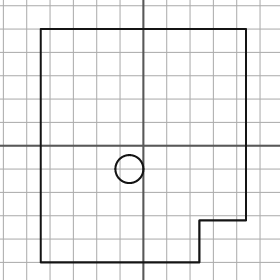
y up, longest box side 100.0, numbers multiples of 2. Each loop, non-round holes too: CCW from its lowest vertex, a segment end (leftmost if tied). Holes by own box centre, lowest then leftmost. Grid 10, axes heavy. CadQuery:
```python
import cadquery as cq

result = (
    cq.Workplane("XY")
    .moveTo(-44.0, -50.0)
    .lineTo(24.0, -50.0)
    .lineTo(24.0, -32.0)
    .lineTo(44.0, -32.0)
    .lineTo(44.0, 50.0)
    .lineTo(-44.0, 50.0)
    .close()
    .moveTo(-6.0, -10.0)
    .circle(6.0)
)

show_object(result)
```